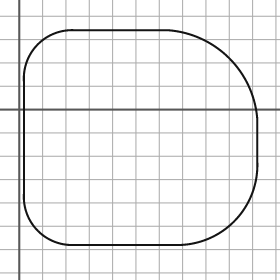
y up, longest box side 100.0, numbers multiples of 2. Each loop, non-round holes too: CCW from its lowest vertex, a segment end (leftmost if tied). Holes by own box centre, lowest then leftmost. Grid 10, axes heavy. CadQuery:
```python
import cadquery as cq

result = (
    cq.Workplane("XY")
    .moveTo(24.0, -58.0)
    .lineTo(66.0, -58.0)
    .threePointArc((92.0, -48.0), (102.0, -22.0))
    .lineTo(102.0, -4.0)
    .threePointArc((90.0, 22.0), (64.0, 34.0))
    .lineTo(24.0, 34.0)
    .threePointArc((8.0, 28.0), (2.0, 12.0))
    .lineTo(2.0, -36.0)
    .threePointArc((8.0, -52.0), (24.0, -58.0))
    .close()
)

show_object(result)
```